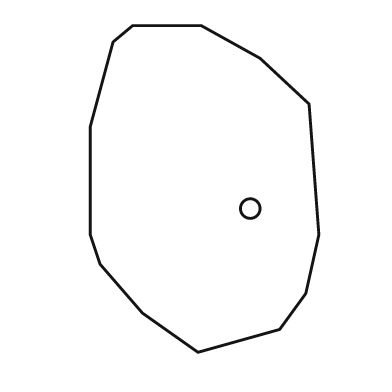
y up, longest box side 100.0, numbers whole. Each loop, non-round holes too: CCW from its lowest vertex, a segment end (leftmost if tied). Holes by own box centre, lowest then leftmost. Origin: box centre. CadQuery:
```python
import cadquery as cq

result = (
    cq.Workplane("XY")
    .moveTo(-2.0, -50.0)
    .lineTo(23.0, -43.0)
    .lineTo(31.0, -32.0)
    .lineTo(35.0, -14.0)
    .lineTo(32.0, 26.0)
    .lineTo(17.0, 40.0)
    .lineTo(-1.0, 50.0)
    .lineTo(-22.0, 50.0)
    .lineTo(-28.0, 45.0)
    .lineTo(-35.0, 19.0)
    .lineTo(-35.0, -14.0)
    .lineTo(-32.0, -23.0)
    .lineTo(-19.0, -38.0)
    .close()
    .moveTo(14.0, -6.0)
    .circle(3.0)
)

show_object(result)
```